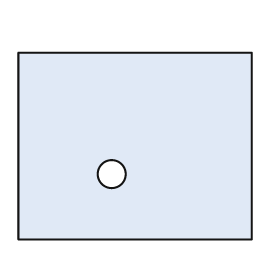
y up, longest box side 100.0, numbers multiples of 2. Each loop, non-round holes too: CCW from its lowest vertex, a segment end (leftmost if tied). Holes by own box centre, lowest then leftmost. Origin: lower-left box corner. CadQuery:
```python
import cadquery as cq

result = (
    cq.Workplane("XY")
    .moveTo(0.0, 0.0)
    .lineTo(100.0, 0.0)
    .lineTo(100.0, 80.0)
    .lineTo(0.0, 80.0)
    .close()
    .moveTo(40.0, 28.0)
    .circle(6.0)
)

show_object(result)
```